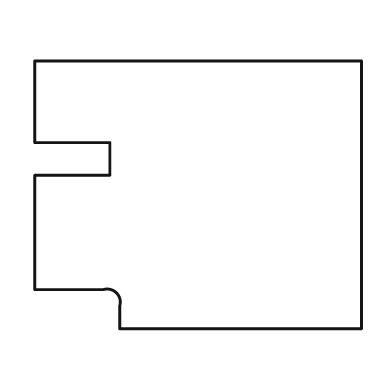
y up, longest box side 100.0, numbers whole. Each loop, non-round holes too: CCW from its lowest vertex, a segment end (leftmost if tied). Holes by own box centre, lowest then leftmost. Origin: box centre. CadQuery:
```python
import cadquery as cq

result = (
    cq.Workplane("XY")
    .moveTo(-24.0, -41.0)
    .lineTo(50.0, -41.0)
    .lineTo(50.0, 41.0)
    .lineTo(-50.0, 41.0)
    .lineTo(-50.0, 16.0)
    .lineTo(-27.0, 16.0)
    .lineTo(-27.0, 6.0)
    .lineTo(-50.0, 6.0)
    .lineTo(-50.0, -29.0)
    .lineTo(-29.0, -29.0)
    .threePointArc((-25.0, -30.0), (-24.0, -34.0))
    .close()
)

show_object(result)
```